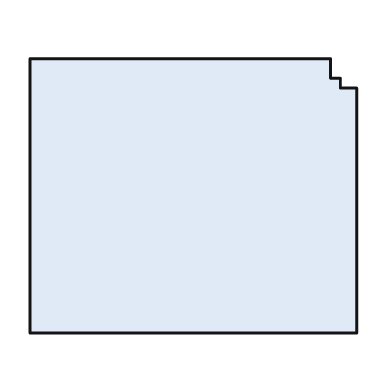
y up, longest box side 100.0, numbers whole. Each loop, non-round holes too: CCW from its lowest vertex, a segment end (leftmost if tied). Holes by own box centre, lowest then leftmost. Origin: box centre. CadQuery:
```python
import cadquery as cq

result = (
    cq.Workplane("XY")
    .moveTo(-50.0, -42.0)
    .lineTo(50.0, -42.0)
    .lineTo(50.0, 33.0)
    .lineTo(45.0, 33.0)
    .lineTo(45.0, 36.0)
    .lineTo(42.0, 36.0)
    .lineTo(42.0, 42.0)
    .lineTo(-50.0, 42.0)
    .close()
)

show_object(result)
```